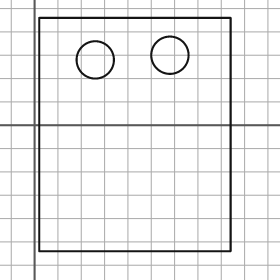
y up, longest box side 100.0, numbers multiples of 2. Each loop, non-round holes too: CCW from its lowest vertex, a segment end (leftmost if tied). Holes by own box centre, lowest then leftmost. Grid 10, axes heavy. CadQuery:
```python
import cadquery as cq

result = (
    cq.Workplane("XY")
    .moveTo(2.0, -54.0)
    .lineTo(84.0, -54.0)
    .lineTo(84.0, 46.0)
    .lineTo(2.0, 46.0)
    .close()
    .moveTo(26.0, 28.0)
    .circle(8.0)
    .moveTo(58.0, 30.0)
    .circle(8.0)
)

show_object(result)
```